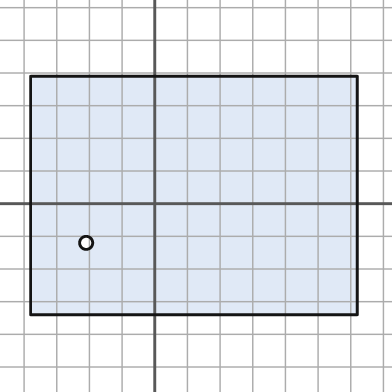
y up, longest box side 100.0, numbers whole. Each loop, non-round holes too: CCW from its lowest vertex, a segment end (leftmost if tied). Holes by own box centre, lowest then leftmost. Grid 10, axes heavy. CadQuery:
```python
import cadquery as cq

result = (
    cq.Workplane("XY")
    .moveTo(-38.0, -34.0)
    .lineTo(62.0, -34.0)
    .lineTo(62.0, 39.0)
    .lineTo(-38.0, 39.0)
    .close()
    .moveTo(-21.0, -12.0)
    .circle(2.0)
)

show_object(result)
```